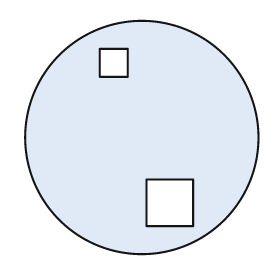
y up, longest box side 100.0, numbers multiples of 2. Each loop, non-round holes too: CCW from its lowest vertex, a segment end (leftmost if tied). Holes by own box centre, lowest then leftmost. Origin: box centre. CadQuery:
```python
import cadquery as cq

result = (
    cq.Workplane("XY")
    .moveTo(0.0, 0.0)
    .circle(50.0)
    .moveTo(2.0, -38.0)
    .lineTo(22.0, -38.0)
    .lineTo(22.0, -18.0)
    .lineTo(2.0, -18.0)
    .close()
    .moveTo(-18.0, 26.0)
    .lineTo(-6.0, 26.0)
    .lineTo(-6.0, 38.0)
    .lineTo(-18.0, 38.0)
    .close()
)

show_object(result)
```